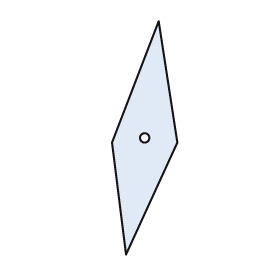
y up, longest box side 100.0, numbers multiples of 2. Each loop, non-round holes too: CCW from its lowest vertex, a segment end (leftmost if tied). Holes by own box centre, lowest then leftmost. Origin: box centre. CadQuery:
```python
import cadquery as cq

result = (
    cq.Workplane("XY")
    .moveTo(-8.0, -50.0)
    .lineTo(14.0, -2.0)
    .lineTo(6.0, 50.0)
    .lineTo(-14.0, -2.0)
    .close()
    .moveTo(0.0, 0.0)
    .circle(2.0)
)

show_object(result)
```